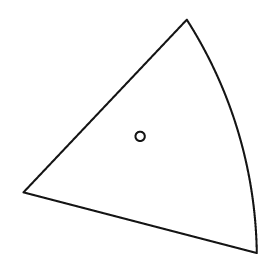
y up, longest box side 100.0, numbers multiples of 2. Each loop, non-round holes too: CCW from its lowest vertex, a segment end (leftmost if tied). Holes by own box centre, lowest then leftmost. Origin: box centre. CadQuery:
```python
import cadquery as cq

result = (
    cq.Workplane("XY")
    .moveTo(50.0, -50.0)
    .threePointArc((42.0, 2.0), (20.0, 50.0))
    .lineTo(-50.0, -24.0)
    .close()
    .moveTo(0.0, 0.0)
    .circle(2.0)
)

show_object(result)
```